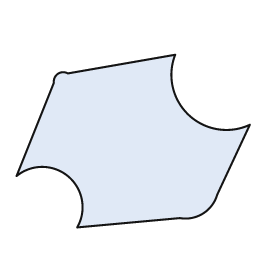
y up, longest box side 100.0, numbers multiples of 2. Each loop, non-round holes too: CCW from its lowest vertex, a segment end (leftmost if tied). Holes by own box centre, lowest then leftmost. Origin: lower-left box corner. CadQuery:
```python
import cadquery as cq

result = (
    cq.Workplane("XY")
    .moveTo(26.0, 0.0)
    .lineTo(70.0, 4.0)
    .threePointArc((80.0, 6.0), (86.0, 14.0))
    .lineTo(100.0, 44.0)
    .threePointArc((74.0, 48.0), (68.0, 74.0))
    .lineTo(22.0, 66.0)
    .threePointArc((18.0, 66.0), (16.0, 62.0))
    .lineTo(0.0, 22.0)
    .threePointArc((22.0, 22.0), (26.0, 0.0))
    .close()
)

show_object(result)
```